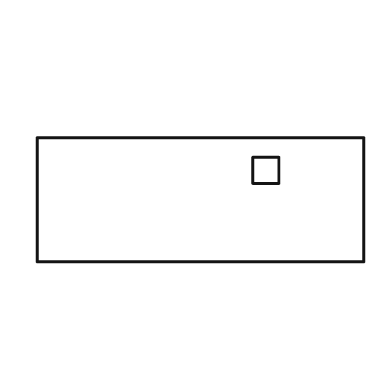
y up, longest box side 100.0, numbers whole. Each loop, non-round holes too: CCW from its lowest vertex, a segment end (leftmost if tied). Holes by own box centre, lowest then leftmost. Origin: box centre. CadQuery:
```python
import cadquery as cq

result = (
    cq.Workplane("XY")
    .moveTo(-50.0, -19.0)
    .lineTo(50.0, -19.0)
    .lineTo(50.0, 19.0)
    .lineTo(-50.0, 19.0)
    .close()
    .moveTo(16.0, 5.0)
    .lineTo(24.0, 5.0)
    .lineTo(24.0, 13.0)
    .lineTo(16.0, 13.0)
    .close()
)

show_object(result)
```